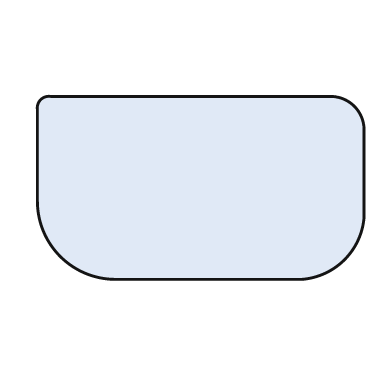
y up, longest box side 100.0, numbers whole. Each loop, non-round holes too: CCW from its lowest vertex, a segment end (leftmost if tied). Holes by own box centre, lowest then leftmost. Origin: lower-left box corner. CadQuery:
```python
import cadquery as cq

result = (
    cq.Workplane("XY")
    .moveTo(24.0, 0.0)
    .lineTo(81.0, 0.0)
    .threePointArc((94.0, 6.0), (100.0, 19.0))
    .lineTo(100.0, 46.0)
    .threePointArc((97.0, 53.0), (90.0, 56.0))
    .lineTo(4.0, 56.0)
    .threePointArc((1.0, 55.0), (0.0, 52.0))
    .lineTo(0.0, 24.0)
    .threePointArc((7.0, 7.0), (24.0, 0.0))
    .close()
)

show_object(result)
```